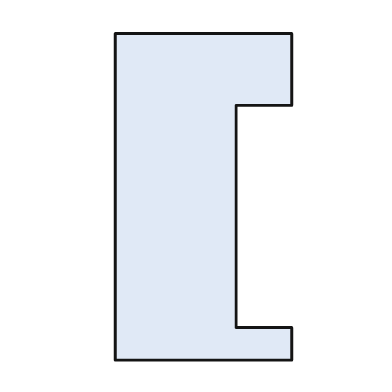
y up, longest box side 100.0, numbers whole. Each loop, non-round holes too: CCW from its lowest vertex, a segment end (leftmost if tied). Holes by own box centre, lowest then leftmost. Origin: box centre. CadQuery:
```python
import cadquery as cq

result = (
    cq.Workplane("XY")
    .moveTo(-27.0, -50.0)
    .lineTo(27.0, -50.0)
    .lineTo(27.0, -40.0)
    .lineTo(10.0, -40.0)
    .lineTo(10.0, 28.0)
    .lineTo(27.0, 28.0)
    .lineTo(27.0, 50.0)
    .lineTo(-27.0, 50.0)
    .close()
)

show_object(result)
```